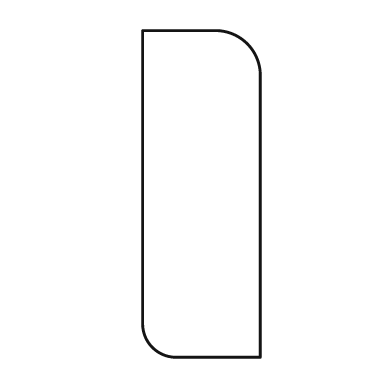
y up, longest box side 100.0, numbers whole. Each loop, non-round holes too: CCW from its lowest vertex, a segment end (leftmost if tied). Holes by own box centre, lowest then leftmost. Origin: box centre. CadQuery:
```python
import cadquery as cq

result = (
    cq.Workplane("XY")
    .moveTo(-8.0, -50.0)
    .lineTo(18.0, -50.0)
    .lineTo(18.0, 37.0)
    .threePointArc((14.0, 46.0), (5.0, 50.0))
    .lineTo(-18.0, 50.0)
    .lineTo(-18.0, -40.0)
    .threePointArc((-15.0, -47.0), (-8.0, -50.0))
    .close()
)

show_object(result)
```